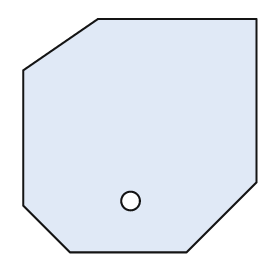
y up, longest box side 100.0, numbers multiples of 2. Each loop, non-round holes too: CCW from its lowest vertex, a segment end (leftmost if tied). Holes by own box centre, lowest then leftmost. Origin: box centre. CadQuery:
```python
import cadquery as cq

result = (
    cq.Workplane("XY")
    .moveTo(-30.0, -50.0)
    .lineTo(20.0, -50.0)
    .lineTo(50.0, -20.0)
    .lineTo(50.0, 50.0)
    .lineTo(-18.0, 50.0)
    .lineTo(-50.0, 28.0)
    .lineTo(-50.0, -30.0)
    .close()
    .moveTo(-4.0, -28.0)
    .circle(4.0)
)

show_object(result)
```